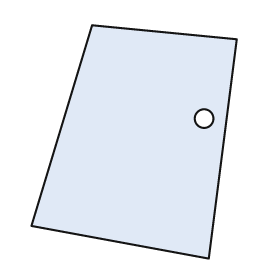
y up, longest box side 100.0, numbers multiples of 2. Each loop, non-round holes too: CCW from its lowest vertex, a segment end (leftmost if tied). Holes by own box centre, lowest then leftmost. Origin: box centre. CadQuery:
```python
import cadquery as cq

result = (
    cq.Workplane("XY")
    .moveTo(32.0, -50.0)
    .lineTo(44.0, 44.0)
    .lineTo(-18.0, 50.0)
    .lineTo(-44.0, -36.0)
    .close()
    .moveTo(30.0, 10.0)
    .circle(4.0)
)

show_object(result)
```